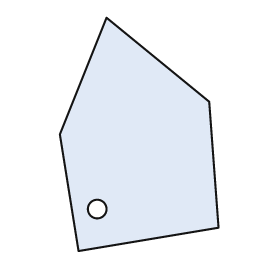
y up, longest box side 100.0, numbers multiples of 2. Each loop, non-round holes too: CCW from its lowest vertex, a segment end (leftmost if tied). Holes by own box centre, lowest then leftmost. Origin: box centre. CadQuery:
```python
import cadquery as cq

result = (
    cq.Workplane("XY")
    .moveTo(-26.0, -50.0)
    .lineTo(34.0, -40.0)
    .lineTo(30.0, 14.0)
    .lineTo(-14.0, 50.0)
    .lineTo(-34.0, 0.0)
    .close()
    .moveTo(-18.0, -32.0)
    .circle(4.0)
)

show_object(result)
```